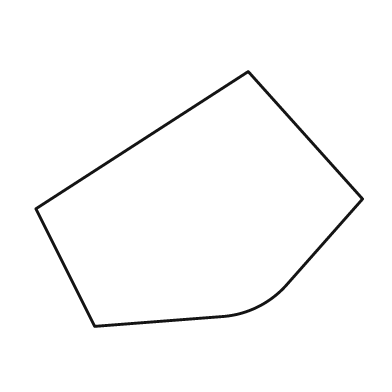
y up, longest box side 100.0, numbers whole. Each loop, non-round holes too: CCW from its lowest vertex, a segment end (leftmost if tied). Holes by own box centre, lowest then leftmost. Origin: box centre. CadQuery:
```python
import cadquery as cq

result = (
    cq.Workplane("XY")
    .moveTo(-32.0, -39.0)
    .lineTo(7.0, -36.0)
    .threePointArc((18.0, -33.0), (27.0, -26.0))
    .lineTo(50.0, 0.0)
    .lineTo(15.0, 39.0)
    .lineTo(-50.0, -3.0)
    .close()
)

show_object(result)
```